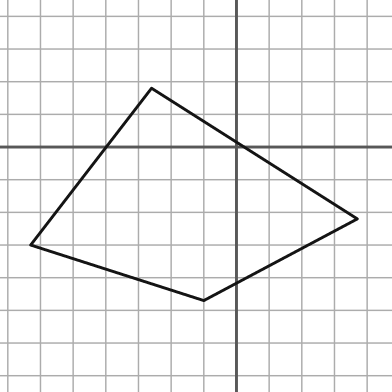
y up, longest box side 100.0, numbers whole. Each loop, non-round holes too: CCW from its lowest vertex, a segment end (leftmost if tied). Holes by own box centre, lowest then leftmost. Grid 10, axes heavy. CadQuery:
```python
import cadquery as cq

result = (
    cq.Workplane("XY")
    .moveTo(-10.0, -47.0)
    .lineTo(37.0, -22.0)
    .lineTo(-26.0, 18.0)
    .lineTo(-63.0, -30.0)
    .close()
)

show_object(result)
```